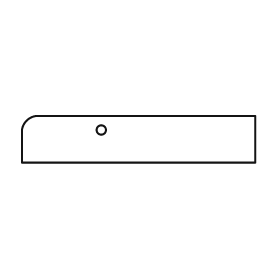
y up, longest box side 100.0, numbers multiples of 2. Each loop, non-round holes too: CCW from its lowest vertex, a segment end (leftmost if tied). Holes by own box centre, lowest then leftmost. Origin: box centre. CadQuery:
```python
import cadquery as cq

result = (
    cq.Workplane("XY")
    .moveTo(-50.0, -10.0)
    .lineTo(50.0, -10.0)
    .lineTo(50.0, 10.0)
    .lineTo(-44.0, 10.0)
    .threePointArc((-48.0, 8.0), (-50.0, 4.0))
    .close()
    .moveTo(-16.0, 4.0)
    .circle(2.0)
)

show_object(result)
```